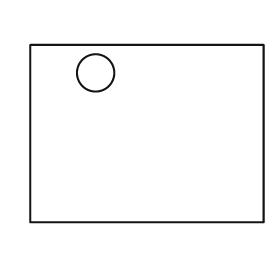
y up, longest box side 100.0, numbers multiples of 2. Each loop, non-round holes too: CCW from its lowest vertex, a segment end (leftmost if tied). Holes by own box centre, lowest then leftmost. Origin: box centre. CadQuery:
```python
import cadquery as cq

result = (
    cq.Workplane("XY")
    .moveTo(-50.0, -38.0)
    .lineTo(50.0, -38.0)
    .lineTo(50.0, 38.0)
    .lineTo(-50.0, 38.0)
    .close()
    .moveTo(-22.0, 26.0)
    .circle(8.0)
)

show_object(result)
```